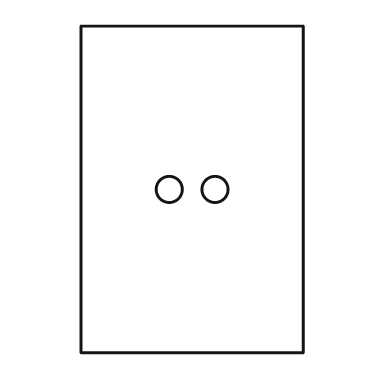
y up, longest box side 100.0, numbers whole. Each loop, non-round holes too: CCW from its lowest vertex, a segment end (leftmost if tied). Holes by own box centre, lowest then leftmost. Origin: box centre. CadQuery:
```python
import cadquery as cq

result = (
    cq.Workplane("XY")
    .moveTo(-34.0, -50.0)
    .lineTo(34.0, -50.0)
    .lineTo(34.0, 50.0)
    .lineTo(-34.0, 50.0)
    .close()
    .moveTo(-7.0, 0.0)
    .circle(4.0)
    .moveTo(7.0, 0.0)
    .circle(4.0)
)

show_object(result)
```